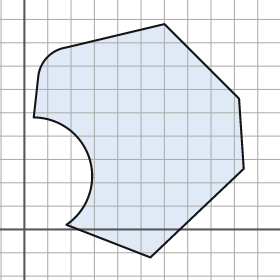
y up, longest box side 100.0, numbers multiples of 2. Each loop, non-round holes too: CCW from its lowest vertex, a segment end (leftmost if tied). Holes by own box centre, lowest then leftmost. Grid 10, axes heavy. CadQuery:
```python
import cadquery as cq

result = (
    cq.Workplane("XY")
    .moveTo(54.0, -12.0)
    .lineTo(94.0, 26.0)
    .lineTo(92.0, 56.0)
    .lineTo(60.0, 88.0)
    .lineTo(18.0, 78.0)
    .threePointArc((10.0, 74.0), (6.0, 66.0))
    .lineTo(4.0, 48.0)
    .threePointArc((28.0, 30.0), (18.0, 2.0))
    .close()
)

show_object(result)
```